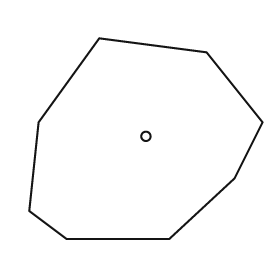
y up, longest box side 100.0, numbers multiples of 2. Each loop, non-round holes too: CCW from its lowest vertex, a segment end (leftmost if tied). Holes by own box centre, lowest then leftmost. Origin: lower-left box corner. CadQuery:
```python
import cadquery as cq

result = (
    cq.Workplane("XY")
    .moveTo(16.0, 0.0)
    .lineTo(60.0, 0.0)
    .lineTo(88.0, 26.0)
    .lineTo(100.0, 50.0)
    .lineTo(76.0, 80.0)
    .lineTo(30.0, 86.0)
    .lineTo(4.0, 50.0)
    .lineTo(0.0, 12.0)
    .close()
    .moveTo(50.0, 44.0)
    .circle(2.0)
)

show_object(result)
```